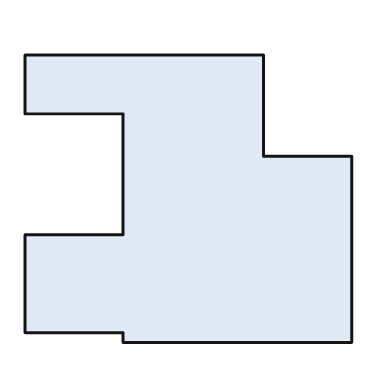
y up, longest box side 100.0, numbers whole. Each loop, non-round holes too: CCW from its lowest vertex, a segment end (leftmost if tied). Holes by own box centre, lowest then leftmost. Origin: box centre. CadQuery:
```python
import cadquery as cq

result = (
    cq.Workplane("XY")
    .moveTo(-20.0, -44.0)
    .lineTo(50.0, -44.0)
    .lineTo(50.0, 13.0)
    .lineTo(23.0, 13.0)
    .lineTo(23.0, 44.0)
    .lineTo(-50.0, 44.0)
    .lineTo(-50.0, 26.0)
    .lineTo(-20.0, 26.0)
    .lineTo(-20.0, -11.0)
    .lineTo(-50.0, -11.0)
    .lineTo(-50.0, -41.0)
    .lineTo(-20.0, -41.0)
    .close()
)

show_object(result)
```